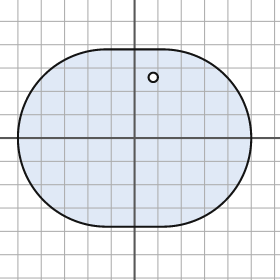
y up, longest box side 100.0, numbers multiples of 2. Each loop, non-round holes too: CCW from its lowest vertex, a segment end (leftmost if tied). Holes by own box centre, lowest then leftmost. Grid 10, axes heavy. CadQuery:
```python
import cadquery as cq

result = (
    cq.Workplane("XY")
    .moveTo(-12.0, -38.0)
    .lineTo(12.0, -38.0)
    .threePointArc((50.0, 0.0), (12.0, 38.0))
    .lineTo(-12.0, 38.0)
    .threePointArc((-50.0, 0.0), (-12.0, -38.0))
    .close()
    .moveTo(8.0, 26.0)
    .circle(2.0)
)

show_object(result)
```